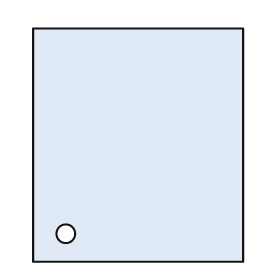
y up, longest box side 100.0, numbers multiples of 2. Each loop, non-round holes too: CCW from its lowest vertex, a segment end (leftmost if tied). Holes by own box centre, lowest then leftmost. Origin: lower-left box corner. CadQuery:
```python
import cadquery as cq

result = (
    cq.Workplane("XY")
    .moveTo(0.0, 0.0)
    .lineTo(90.0, 0.0)
    .lineTo(90.0, 100.0)
    .lineTo(0.0, 100.0)
    .close()
    .moveTo(14.0, 12.0)
    .circle(4.0)
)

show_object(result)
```